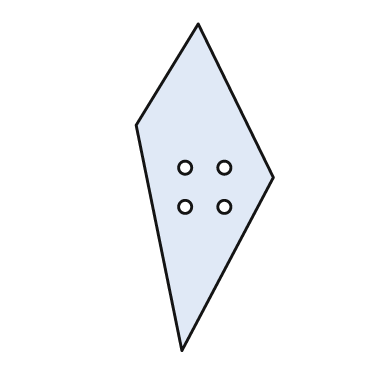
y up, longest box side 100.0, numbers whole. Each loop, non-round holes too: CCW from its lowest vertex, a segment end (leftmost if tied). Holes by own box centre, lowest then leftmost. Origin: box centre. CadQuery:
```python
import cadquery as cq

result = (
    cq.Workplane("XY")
    .moveTo(-7.0, -50.0)
    .lineTo(21.0, 3.0)
    .lineTo(-2.0, 50.0)
    .lineTo(-21.0, 19.0)
    .close()
    .moveTo(-6.0, -6.0)
    .circle(2.0)
    .moveTo(6.0, -6.0)
    .circle(2.0)
    .moveTo(-6.0, 6.0)
    .circle(2.0)
    .moveTo(6.0, 6.0)
    .circle(2.0)
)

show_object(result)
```